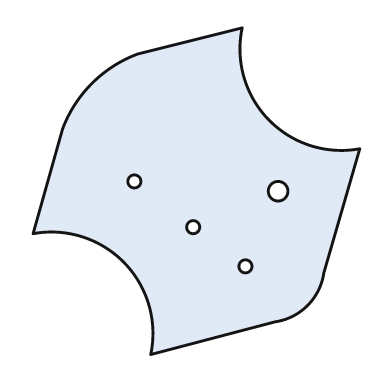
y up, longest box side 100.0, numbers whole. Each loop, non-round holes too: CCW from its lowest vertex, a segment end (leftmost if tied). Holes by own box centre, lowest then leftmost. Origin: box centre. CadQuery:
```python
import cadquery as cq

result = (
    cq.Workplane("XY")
    .moveTo(-14.0, -50.0)
    .lineTo(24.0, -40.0)
    .threePointArc((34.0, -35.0), (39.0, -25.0))
    .lineTo(50.0, 13.0)
    .threePointArc((22.0, 22.0), (14.0, 50.0))
    .lineTo(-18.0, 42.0)
    .threePointArc((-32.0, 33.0), (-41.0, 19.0))
    .lineTo(-50.0, -13.0)
    .threePointArc((-22.0, -22.0), (-14.0, -50.0))
    .close()
    .moveTo(15.0, -23.0)
    .circle(2.0)
    .moveTo(-1.0, -11.0)
    .circle(2.0)
    .moveTo(25.0, 0.0)
    .circle(3.0)
    .moveTo(-19.0, 3.0)
    .circle(2.0)
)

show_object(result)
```